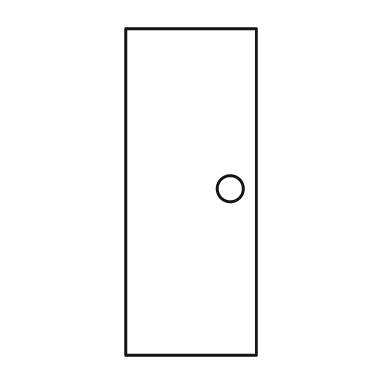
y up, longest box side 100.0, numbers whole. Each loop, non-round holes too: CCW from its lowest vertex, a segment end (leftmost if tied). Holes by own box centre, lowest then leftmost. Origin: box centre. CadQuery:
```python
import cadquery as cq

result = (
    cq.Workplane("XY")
    .moveTo(-20.0, -50.0)
    .lineTo(20.0, -50.0)
    .lineTo(20.0, 50.0)
    .lineTo(-20.0, 50.0)
    .close()
    .moveTo(12.0, 1.0)
    .circle(4.0)
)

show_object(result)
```